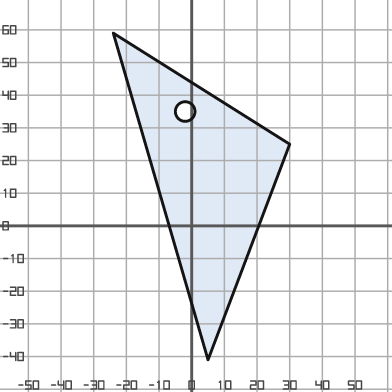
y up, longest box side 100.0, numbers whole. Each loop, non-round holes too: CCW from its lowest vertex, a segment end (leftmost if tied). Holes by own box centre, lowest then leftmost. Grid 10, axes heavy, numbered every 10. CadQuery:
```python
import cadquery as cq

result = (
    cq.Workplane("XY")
    .moveTo(5.0, -41.0)
    .lineTo(30.0, 25.0)
    .lineTo(-24.0, 59.0)
    .close()
    .moveTo(-2.0, 35.0)
    .circle(3.0)
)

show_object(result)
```